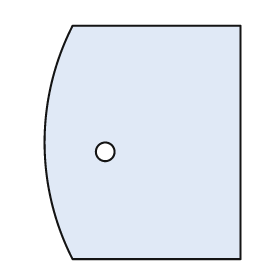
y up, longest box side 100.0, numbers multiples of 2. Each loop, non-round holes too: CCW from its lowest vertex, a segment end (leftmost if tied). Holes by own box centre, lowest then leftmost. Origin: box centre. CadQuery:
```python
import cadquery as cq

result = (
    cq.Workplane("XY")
    .moveTo(-30.0, -50.0)
    .lineTo(42.0, -50.0)
    .lineTo(42.0, 50.0)
    .lineTo(-30.0, 50.0)
    .threePointArc((-42.0, 0.0), (-30.0, -50.0))
    .close()
    .moveTo(-16.0, -4.0)
    .circle(4.0)
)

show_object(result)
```